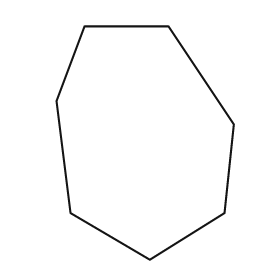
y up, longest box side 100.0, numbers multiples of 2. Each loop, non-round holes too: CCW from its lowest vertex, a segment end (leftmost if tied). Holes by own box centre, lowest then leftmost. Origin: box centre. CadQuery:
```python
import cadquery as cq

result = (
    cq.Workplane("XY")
    .moveTo(2.0, -50.0)
    .lineTo(34.0, -30.0)
    .lineTo(38.0, 8.0)
    .lineTo(10.0, 50.0)
    .lineTo(-26.0, 50.0)
    .lineTo(-38.0, 18.0)
    .lineTo(-32.0, -30.0)
    .close()
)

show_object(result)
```